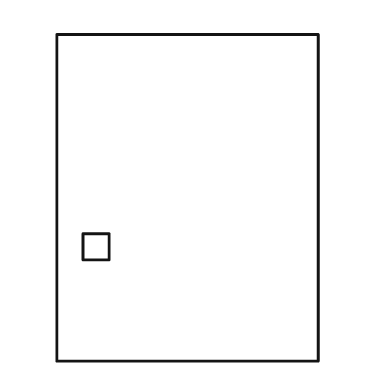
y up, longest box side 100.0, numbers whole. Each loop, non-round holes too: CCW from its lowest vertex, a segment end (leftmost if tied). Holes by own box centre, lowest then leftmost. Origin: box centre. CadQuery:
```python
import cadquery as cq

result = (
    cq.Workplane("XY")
    .moveTo(-40.0, -50.0)
    .lineTo(40.0, -50.0)
    .lineTo(40.0, 50.0)
    .lineTo(-40.0, 50.0)
    .close()
    .moveTo(-32.0, -19.0)
    .lineTo(-24.0, -19.0)
    .lineTo(-24.0, -11.0)
    .lineTo(-32.0, -11.0)
    .close()
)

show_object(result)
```